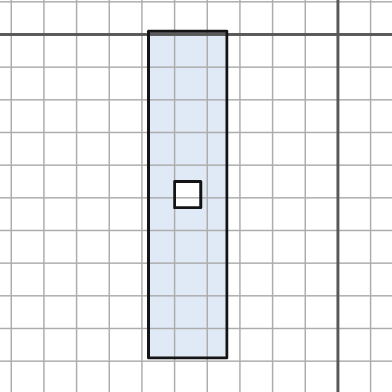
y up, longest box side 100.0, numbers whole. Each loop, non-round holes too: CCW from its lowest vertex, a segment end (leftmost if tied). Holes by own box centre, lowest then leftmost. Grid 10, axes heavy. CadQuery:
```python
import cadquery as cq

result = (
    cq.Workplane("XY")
    .moveTo(-58.0, -99.0)
    .lineTo(-34.0, -99.0)
    .lineTo(-34.0, 1.0)
    .lineTo(-58.0, 1.0)
    .close()
    .moveTo(-50.0, -53.0)
    .lineTo(-42.0, -53.0)
    .lineTo(-42.0, -45.0)
    .lineTo(-50.0, -45.0)
    .close()
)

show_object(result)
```